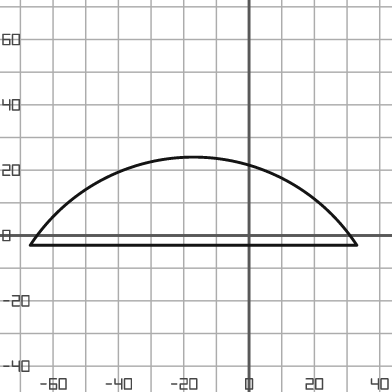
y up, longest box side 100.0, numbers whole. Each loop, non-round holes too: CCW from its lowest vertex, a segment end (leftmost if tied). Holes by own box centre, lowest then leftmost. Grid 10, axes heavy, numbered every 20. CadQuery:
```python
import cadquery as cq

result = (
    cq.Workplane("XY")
    .moveTo(-67.0, -3.0)
    .lineTo(33.0, -3.0)
    .threePointArc((-17.0, 24.0), (-67.0, -3.0))
    .close()
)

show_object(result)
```